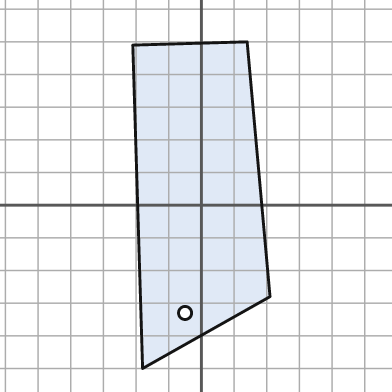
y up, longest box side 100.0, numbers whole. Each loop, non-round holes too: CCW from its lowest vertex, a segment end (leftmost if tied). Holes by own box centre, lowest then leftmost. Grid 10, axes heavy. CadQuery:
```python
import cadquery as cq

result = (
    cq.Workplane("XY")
    .moveTo(-18.0, -50.0)
    .lineTo(21.0, -28.0)
    .lineTo(14.0, 50.0)
    .lineTo(-21.0, 49.0)
    .close()
    .moveTo(-5.0, -33.0)
    .circle(2.0)
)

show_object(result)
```